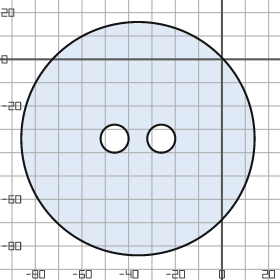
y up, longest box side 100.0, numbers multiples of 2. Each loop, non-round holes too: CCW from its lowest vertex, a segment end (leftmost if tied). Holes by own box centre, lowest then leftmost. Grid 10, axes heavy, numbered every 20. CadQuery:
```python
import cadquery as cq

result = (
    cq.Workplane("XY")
    .moveTo(-36.0, -34.0)
    .circle(50.0)
    .moveTo(-46.0, -34.0)
    .circle(6.0)
    .moveTo(-26.0, -34.0)
    .circle(6.0)
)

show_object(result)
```